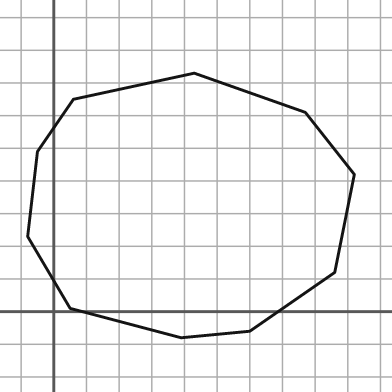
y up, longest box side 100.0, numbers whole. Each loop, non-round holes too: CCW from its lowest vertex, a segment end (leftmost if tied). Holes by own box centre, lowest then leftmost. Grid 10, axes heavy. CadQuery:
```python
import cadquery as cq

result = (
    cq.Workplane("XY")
    .moveTo(39.0, -8.0)
    .lineTo(60.0, -6.0)
    .lineTo(86.0, 12.0)
    .lineTo(92.0, 42.0)
    .lineTo(77.0, 61.0)
    .lineTo(43.0, 73.0)
    .lineTo(6.0, 65.0)
    .lineTo(-5.0, 49.0)
    .lineTo(-8.0, 23.0)
    .lineTo(5.0, 1.0)
    .close()
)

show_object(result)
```